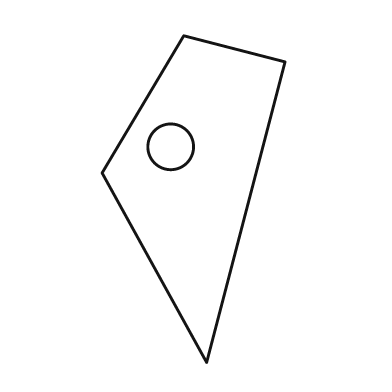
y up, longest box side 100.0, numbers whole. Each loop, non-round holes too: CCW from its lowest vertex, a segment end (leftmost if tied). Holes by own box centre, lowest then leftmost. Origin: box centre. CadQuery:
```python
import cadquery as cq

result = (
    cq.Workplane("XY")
    .moveTo(4.0, -50.0)
    .lineTo(28.0, 42.0)
    .lineTo(-3.0, 50.0)
    .lineTo(-28.0, 8.0)
    .close()
    .moveTo(-7.0, 16.0)
    .circle(7.0)
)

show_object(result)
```